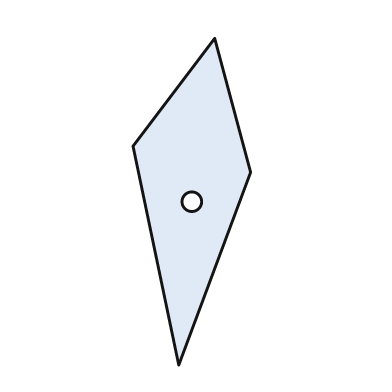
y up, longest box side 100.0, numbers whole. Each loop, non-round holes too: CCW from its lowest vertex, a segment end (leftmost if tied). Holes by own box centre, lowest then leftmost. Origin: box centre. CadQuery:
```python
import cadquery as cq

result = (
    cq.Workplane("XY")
    .moveTo(-4.0, -50.0)
    .lineTo(18.0, 9.0)
    .lineTo(7.0, 50.0)
    .lineTo(-18.0, 17.0)
    .close()
    .moveTo(0.0, 0.0)
    .circle(3.0)
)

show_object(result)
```